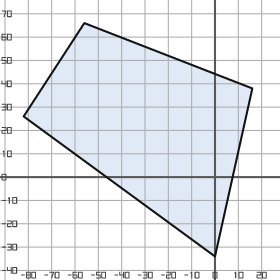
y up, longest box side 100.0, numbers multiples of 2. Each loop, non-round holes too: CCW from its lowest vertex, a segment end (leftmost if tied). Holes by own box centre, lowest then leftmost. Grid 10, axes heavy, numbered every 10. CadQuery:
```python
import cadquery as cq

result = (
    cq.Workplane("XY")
    .moveTo(0.0, -34.0)
    .lineTo(16.0, 38.0)
    .lineTo(-56.0, 66.0)
    .lineTo(-82.0, 26.0)
    .close()
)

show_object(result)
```